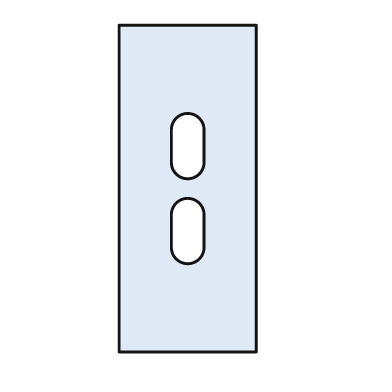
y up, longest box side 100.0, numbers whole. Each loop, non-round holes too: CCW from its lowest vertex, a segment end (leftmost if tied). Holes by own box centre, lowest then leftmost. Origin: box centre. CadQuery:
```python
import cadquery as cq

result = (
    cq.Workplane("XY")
    .moveTo(-21.0, -50.0)
    .lineTo(21.0, -50.0)
    .lineTo(21.0, 50.0)
    .lineTo(-21.0, 50.0)
    .close()
    .moveTo(-5.0, -18.0)
    .threePointArc((0.0, -23.0), (5.0, -18.0))
    .lineTo(5.0, -8.0)
    .threePointArc((0.0, -3.0), (-5.0, -8.0))
    .close()
    .moveTo(-5.0, 8.0)
    .threePointArc((0.0, 3.0), (5.0, 8.0))
    .lineTo(5.0, 18.0)
    .threePointArc((0.0, 23.0), (-5.0, 18.0))
    .close()
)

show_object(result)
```